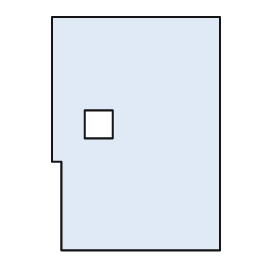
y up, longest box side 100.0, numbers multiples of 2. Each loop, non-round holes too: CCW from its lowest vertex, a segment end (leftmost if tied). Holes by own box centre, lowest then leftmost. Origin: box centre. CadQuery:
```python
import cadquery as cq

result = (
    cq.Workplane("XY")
    .moveTo(-32.0, -50.0)
    .lineTo(36.0, -50.0)
    .lineTo(36.0, 50.0)
    .lineTo(-36.0, 50.0)
    .lineTo(-36.0, -12.0)
    .lineTo(-32.0, -12.0)
    .close()
    .moveTo(-22.0, -2.0)
    .lineTo(-10.0, -2.0)
    .lineTo(-10.0, 10.0)
    .lineTo(-22.0, 10.0)
    .close()
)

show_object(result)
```